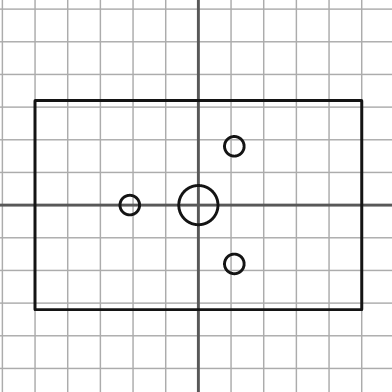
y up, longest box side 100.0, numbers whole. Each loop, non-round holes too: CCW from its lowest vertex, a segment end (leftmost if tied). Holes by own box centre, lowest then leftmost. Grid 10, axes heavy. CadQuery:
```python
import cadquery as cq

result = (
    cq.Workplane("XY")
    .moveTo(-50.0, -32.0)
    .lineTo(50.0, -32.0)
    .lineTo(50.0, 32.0)
    .lineTo(-50.0, 32.0)
    .close()
    .moveTo(11.0, -18.0)
    .circle(3.0)
    .moveTo(-21.0, 0.0)
    .circle(3.0)
    .moveTo(0.0, 0.0)
    .circle(6.0)
    .moveTo(11.0, 18.0)
    .circle(3.0)
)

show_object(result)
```